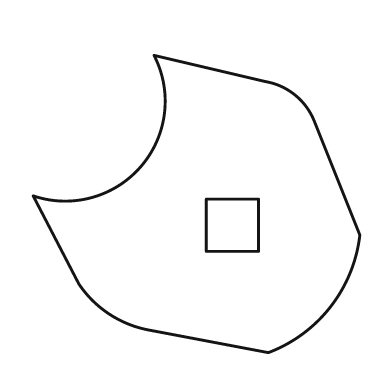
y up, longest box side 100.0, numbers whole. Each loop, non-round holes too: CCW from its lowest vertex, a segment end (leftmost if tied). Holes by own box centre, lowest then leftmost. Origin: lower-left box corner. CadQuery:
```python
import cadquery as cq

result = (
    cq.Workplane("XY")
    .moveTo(72.0, 0.0)
    .threePointArc((91.0, 14.0), (100.0, 36.0))
    .lineTo(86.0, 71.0)
    .threePointArc((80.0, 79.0), (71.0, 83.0))
    .lineTo(37.0, 91.0)
    .threePointArc((33.0, 57.0), (0.0, 48.0))
    .lineTo(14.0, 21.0)
    .threePointArc((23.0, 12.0), (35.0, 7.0))
    .close()
    .moveTo(53.0, 31.0)
    .lineTo(69.0, 31.0)
    .lineTo(69.0, 47.0)
    .lineTo(53.0, 47.0)
    .close()
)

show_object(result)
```